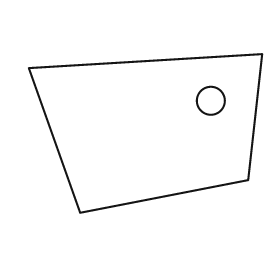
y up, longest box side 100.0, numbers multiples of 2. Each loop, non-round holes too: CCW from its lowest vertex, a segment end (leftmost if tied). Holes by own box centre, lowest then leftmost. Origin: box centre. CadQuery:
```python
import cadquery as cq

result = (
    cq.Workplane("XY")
    .moveTo(-28.0, -34.0)
    .lineTo(44.0, -20.0)
    .lineTo(50.0, 34.0)
    .lineTo(-50.0, 28.0)
    .close()
    .moveTo(28.0, 14.0)
    .circle(6.0)
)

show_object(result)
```